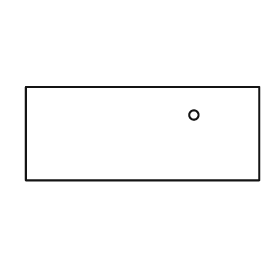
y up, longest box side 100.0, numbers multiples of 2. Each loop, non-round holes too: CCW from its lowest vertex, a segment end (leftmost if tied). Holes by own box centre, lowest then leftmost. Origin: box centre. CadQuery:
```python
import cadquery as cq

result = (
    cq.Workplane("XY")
    .moveTo(-50.0, -20.0)
    .lineTo(50.0, -20.0)
    .lineTo(50.0, 20.0)
    .lineTo(-50.0, 20.0)
    .close()
    .moveTo(22.0, 8.0)
    .circle(2.0)
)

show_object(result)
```